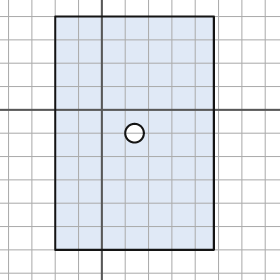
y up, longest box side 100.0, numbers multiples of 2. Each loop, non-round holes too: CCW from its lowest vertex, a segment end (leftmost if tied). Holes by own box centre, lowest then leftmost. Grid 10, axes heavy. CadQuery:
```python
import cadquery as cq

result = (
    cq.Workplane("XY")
    .moveTo(-20.0, -60.0)
    .lineTo(48.0, -60.0)
    .lineTo(48.0, 40.0)
    .lineTo(-20.0, 40.0)
    .close()
    .moveTo(14.0, -10.0)
    .circle(4.0)
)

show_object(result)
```